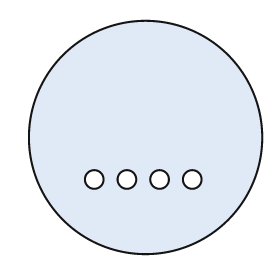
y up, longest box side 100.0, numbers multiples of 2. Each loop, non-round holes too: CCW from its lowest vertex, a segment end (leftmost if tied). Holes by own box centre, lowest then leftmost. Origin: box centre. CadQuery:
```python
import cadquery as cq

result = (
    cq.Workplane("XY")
    .moveTo(0.0, 0.0)
    .circle(50.0)
    .moveTo(-22.0, -18.0)
    .circle(4.0)
    .moveTo(-8.0, -18.0)
    .circle(4.0)
    .moveTo(6.0, -18.0)
    .circle(4.0)
    .moveTo(20.0, -18.0)
    .circle(4.0)
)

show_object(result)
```